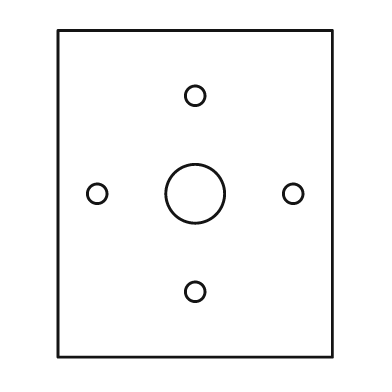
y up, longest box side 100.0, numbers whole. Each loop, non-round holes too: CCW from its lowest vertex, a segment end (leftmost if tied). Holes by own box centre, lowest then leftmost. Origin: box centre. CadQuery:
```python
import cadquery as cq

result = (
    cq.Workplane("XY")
    .moveTo(-42.0, -50.0)
    .lineTo(42.0, -50.0)
    .lineTo(42.0, 50.0)
    .lineTo(-42.0, 50.0)
    .close()
    .moveTo(0.0, -30.0)
    .circle(3.0)
    .moveTo(-30.0, 0.0)
    .circle(3.0)
    .moveTo(0.0, 0.0)
    .circle(9.0)
    .moveTo(30.0, 0.0)
    .circle(3.0)
    .moveTo(0.0, 30.0)
    .circle(3.0)
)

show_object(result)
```